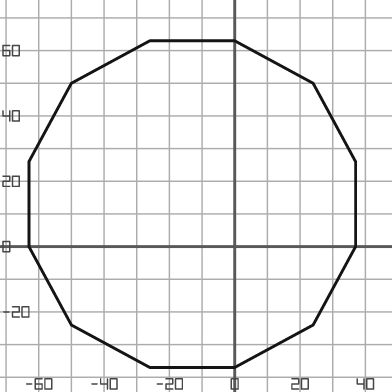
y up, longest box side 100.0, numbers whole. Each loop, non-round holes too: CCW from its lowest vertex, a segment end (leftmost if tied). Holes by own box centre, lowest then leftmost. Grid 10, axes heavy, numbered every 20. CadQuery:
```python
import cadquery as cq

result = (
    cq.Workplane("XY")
    .moveTo(-26.0, -37.0)
    .lineTo(0.0, -37.0)
    .lineTo(24.0, -24.0)
    .lineTo(37.0, 0.0)
    .lineTo(37.0, 26.0)
    .lineTo(24.0, 50.0)
    .lineTo(0.0, 63.0)
    .lineTo(-26.0, 63.0)
    .lineTo(-50.0, 50.0)
    .lineTo(-63.0, 26.0)
    .lineTo(-63.0, 0.0)
    .lineTo(-50.0, -24.0)
    .close()
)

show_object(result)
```